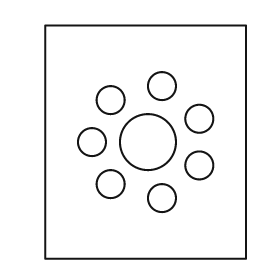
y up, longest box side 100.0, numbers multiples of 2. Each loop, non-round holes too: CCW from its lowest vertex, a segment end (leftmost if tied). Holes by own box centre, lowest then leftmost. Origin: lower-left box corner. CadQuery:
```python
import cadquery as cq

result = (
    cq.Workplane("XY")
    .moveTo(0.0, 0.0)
    .lineTo(86.0, 0.0)
    .lineTo(86.0, 100.0)
    .lineTo(0.0, 100.0)
    .close()
    .moveTo(50.0, 26.0)
    .circle(6.0)
    .moveTo(28.0, 32.0)
    .circle(6.0)
    .moveTo(66.0, 40.0)
    .circle(6.0)
    .moveTo(20.0, 50.0)
    .circle(6.0)
    .moveTo(44.0, 50.0)
    .circle(12.0)
    .moveTo(66.0, 60.0)
    .circle(6.0)
    .moveTo(28.0, 68.0)
    .circle(6.0)
    .moveTo(50.0, 74.0)
    .circle(6.0)
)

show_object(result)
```